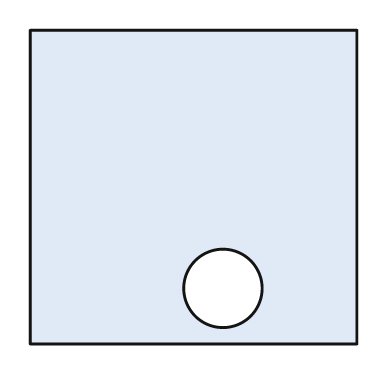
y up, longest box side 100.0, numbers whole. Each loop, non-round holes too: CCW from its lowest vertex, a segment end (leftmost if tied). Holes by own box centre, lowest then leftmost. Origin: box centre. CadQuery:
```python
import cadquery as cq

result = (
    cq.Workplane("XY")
    .moveTo(-50.0, -48.0)
    .lineTo(50.0, -48.0)
    .lineTo(50.0, 48.0)
    .lineTo(-50.0, 48.0)
    .close()
    .moveTo(9.0, -31.0)
    .circle(12.0)
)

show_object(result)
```